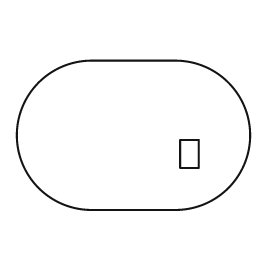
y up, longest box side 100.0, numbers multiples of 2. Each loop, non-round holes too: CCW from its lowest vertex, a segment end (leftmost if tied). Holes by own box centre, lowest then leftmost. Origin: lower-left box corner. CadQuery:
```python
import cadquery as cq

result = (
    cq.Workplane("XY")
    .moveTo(32.0, 0.0)
    .lineTo(68.0, 0.0)
    .threePointArc((100.0, 32.0), (68.0, 64.0))
    .lineTo(32.0, 64.0)
    .threePointArc((0.0, 32.0), (32.0, 0.0))
    .close()
    .moveTo(70.0, 18.0)
    .lineTo(78.0, 18.0)
    .lineTo(78.0, 30.0)
    .lineTo(70.0, 30.0)
    .close()
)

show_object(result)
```